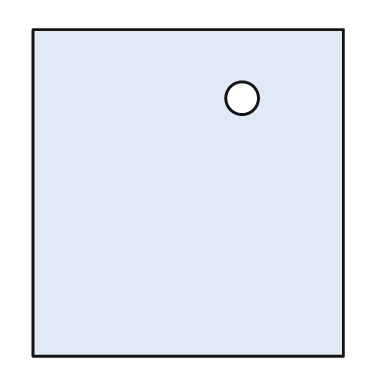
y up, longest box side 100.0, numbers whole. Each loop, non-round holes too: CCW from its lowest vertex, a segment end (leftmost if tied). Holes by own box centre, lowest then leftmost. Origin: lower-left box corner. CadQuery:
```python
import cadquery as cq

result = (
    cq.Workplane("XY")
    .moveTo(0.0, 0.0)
    .lineTo(95.0, 0.0)
    .lineTo(95.0, 100.0)
    .lineTo(0.0, 100.0)
    .close()
    .moveTo(64.0, 79.0)
    .circle(5.0)
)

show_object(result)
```